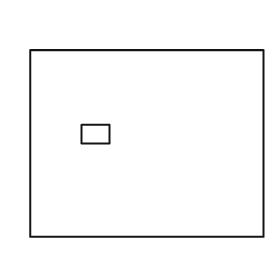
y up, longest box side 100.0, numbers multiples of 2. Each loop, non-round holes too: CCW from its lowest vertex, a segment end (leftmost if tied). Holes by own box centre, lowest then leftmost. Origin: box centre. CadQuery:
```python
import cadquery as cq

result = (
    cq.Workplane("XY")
    .moveTo(-50.0, -40.0)
    .lineTo(50.0, -40.0)
    .lineTo(50.0, 40.0)
    .lineTo(-50.0, 40.0)
    .close()
    .moveTo(-28.0, 0.0)
    .lineTo(-16.0, 0.0)
    .lineTo(-16.0, 8.0)
    .lineTo(-28.0, 8.0)
    .close()
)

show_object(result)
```